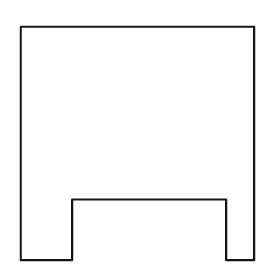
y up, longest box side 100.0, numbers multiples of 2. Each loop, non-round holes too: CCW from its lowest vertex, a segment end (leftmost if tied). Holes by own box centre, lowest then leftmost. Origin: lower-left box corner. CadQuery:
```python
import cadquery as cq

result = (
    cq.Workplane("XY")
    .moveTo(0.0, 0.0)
    .lineTo(22.0, 0.0)
    .lineTo(22.0, 26.0)
    .lineTo(88.0, 26.0)
    .lineTo(88.0, 0.0)
    .lineTo(100.0, 0.0)
    .lineTo(100.0, 100.0)
    .lineTo(0.0, 100.0)
    .close()
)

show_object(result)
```